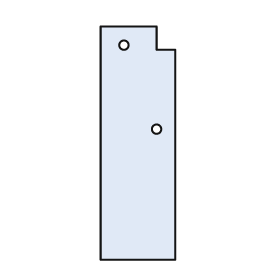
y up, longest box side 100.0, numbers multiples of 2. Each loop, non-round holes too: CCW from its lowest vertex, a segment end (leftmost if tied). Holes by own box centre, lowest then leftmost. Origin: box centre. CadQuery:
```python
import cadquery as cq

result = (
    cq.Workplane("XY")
    .moveTo(-16.0, -50.0)
    .lineTo(16.0, -50.0)
    .lineTo(16.0, 40.0)
    .lineTo(8.0, 40.0)
    .lineTo(8.0, 50.0)
    .lineTo(-16.0, 50.0)
    .close()
    .moveTo(8.0, 6.0)
    .circle(2.0)
    .moveTo(-6.0, 42.0)
    .circle(2.0)
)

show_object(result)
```